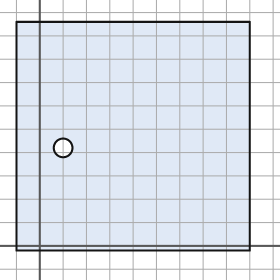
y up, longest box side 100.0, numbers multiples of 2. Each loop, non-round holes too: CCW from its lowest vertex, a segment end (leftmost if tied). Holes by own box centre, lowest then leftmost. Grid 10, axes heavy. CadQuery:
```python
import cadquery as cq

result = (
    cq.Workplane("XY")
    .moveTo(-10.0, -2.0)
    .lineTo(90.0, -2.0)
    .lineTo(90.0, 96.0)
    .lineTo(-10.0, 96.0)
    .close()
    .moveTo(10.0, 42.0)
    .circle(4.0)
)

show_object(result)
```